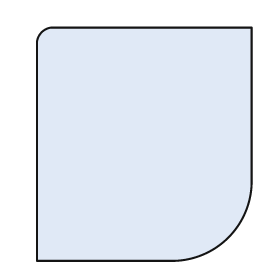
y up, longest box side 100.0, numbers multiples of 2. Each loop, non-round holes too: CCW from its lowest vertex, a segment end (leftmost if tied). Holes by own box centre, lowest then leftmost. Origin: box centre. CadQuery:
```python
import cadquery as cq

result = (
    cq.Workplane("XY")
    .moveTo(-46.0, -50.0)
    .lineTo(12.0, -50.0)
    .threePointArc((36.0, -40.0), (46.0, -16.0))
    .lineTo(46.0, 50.0)
    .lineTo(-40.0, 50.0)
    .threePointArc((-44.0, 48.0), (-46.0, 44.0))
    .close()
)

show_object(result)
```